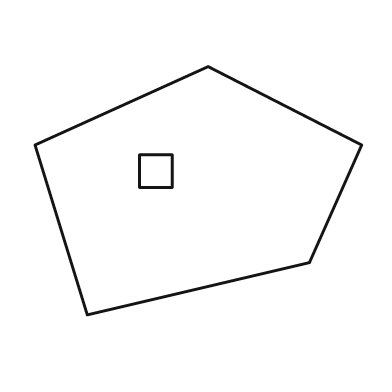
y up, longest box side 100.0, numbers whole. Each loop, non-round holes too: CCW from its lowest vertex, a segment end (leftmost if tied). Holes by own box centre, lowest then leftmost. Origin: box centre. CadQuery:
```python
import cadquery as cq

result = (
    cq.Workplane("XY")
    .moveTo(-34.0, -38.0)
    .lineTo(34.0, -22.0)
    .lineTo(50.0, 14.0)
    .lineTo(3.0, 38.0)
    .lineTo(-50.0, 14.0)
    .close()
    .moveTo(-18.0, 1.0)
    .lineTo(-8.0, 1.0)
    .lineTo(-8.0, 11.0)
    .lineTo(-18.0, 11.0)
    .close()
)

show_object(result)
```